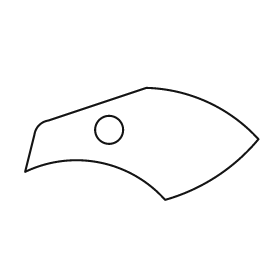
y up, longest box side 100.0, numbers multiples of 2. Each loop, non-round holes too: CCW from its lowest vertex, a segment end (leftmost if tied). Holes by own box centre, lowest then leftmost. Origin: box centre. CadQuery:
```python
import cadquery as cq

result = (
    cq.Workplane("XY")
    .moveTo(10.0, -24.0)
    .threePointArc((32.0, -14.0), (50.0, 2.0))
    .threePointArc((28.0, 18.0), (2.0, 24.0))
    .lineTo(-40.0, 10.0)
    .threePointArc((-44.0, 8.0), (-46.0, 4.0))
    .lineTo(-50.0, -12.0)
    .threePointArc((-18.0, -8.0), (10.0, -24.0))
    .close()
    .moveTo(-14.0, 6.0)
    .circle(6.0)
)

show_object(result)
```